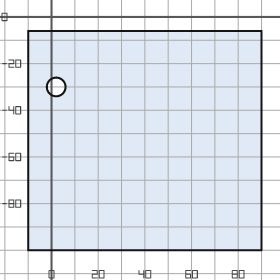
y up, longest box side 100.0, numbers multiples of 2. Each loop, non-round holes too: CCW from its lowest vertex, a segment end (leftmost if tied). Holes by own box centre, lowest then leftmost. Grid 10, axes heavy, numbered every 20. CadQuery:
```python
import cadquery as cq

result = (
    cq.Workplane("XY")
    .moveTo(-10.0, -100.0)
    .lineTo(90.0, -100.0)
    .lineTo(90.0, -6.0)
    .lineTo(-10.0, -6.0)
    .close()
    .moveTo(2.0, -30.0)
    .circle(4.0)
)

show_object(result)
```